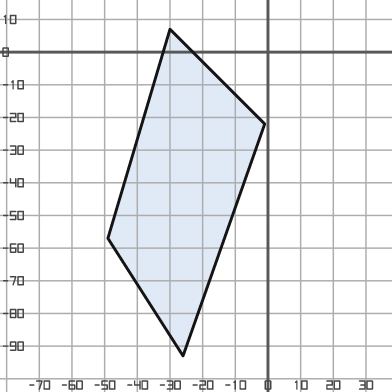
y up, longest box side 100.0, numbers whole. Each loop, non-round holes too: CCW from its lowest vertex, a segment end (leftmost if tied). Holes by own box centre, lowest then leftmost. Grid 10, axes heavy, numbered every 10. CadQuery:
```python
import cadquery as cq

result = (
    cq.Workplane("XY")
    .moveTo(-26.0, -93.0)
    .lineTo(-1.0, -22.0)
    .lineTo(-30.0, 7.0)
    .lineTo(-49.0, -57.0)
    .close()
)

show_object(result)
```